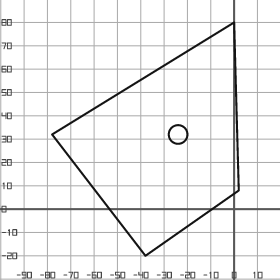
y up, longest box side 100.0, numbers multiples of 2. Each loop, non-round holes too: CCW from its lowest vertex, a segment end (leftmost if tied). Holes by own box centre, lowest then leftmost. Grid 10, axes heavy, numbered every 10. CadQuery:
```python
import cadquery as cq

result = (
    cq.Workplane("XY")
    .moveTo(-38.0, -20.0)
    .lineTo(2.0, 8.0)
    .lineTo(0.0, 80.0)
    .lineTo(-78.0, 32.0)
    .close()
    .moveTo(-24.0, 32.0)
    .circle(4.0)
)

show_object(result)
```